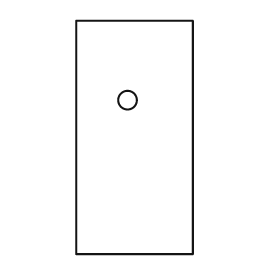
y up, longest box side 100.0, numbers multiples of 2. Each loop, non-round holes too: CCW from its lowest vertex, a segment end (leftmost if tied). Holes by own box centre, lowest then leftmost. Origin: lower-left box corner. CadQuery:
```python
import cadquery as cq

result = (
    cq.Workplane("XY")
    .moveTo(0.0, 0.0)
    .lineTo(50.0, 0.0)
    .lineTo(50.0, 100.0)
    .lineTo(0.0, 100.0)
    .close()
    .moveTo(22.0, 66.0)
    .circle(4.0)
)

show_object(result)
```